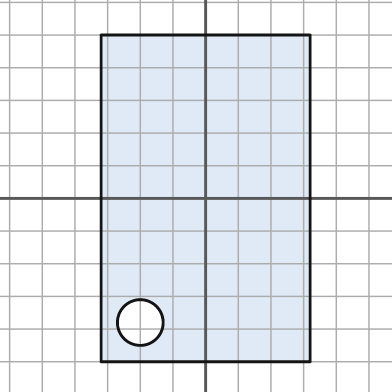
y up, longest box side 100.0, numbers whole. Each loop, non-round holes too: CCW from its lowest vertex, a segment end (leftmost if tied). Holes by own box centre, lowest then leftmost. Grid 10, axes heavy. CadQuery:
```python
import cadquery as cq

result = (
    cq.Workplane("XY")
    .moveTo(-32.0, -50.0)
    .lineTo(32.0, -50.0)
    .lineTo(32.0, 50.0)
    .lineTo(-32.0, 50.0)
    .close()
    .moveTo(-20.0, -38.0)
    .circle(7.0)
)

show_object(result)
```